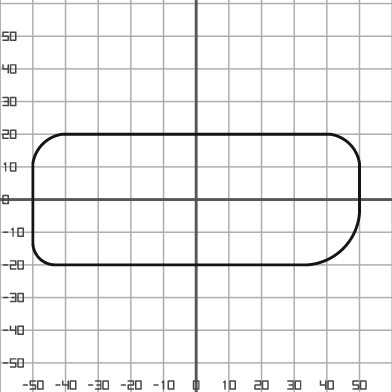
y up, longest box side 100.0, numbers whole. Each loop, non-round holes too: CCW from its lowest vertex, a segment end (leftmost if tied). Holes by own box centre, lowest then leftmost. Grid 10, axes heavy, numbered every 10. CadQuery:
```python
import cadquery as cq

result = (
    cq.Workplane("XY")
    .moveTo(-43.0, -20.0)
    .lineTo(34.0, -20.0)
    .threePointArc((45.0, -15.0), (50.0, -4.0))
    .lineTo(50.0, 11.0)
    .threePointArc((47.0, 17.0), (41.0, 20.0))
    .lineTo(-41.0, 20.0)
    .threePointArc((-47.0, 17.0), (-50.0, 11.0))
    .lineTo(-50.0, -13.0)
    .threePointArc((-48.0, -18.0), (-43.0, -20.0))
    .close()
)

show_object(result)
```